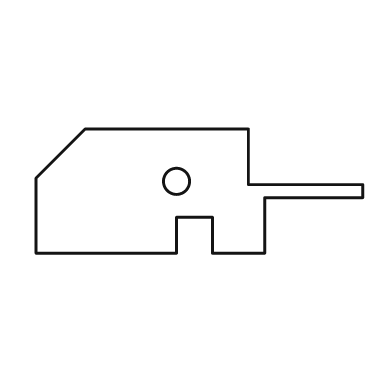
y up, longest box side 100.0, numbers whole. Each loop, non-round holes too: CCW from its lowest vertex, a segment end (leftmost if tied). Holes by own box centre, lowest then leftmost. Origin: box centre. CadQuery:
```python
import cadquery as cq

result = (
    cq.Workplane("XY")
    .moveTo(-50.0, -19.0)
    .lineTo(-7.0, -19.0)
    .lineTo(-7.0, -8.0)
    .lineTo(4.0, -8.0)
    .lineTo(4.0, -19.0)
    .lineTo(20.0, -19.0)
    .lineTo(20.0, -2.0)
    .lineTo(50.0, -2.0)
    .lineTo(50.0, 2.0)
    .lineTo(15.0, 2.0)
    .lineTo(15.0, 19.0)
    .lineTo(-35.0, 19.0)
    .lineTo(-50.0, 4.0)
    .close()
    .moveTo(-7.0, 3.0)
    .circle(4.0)
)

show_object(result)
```